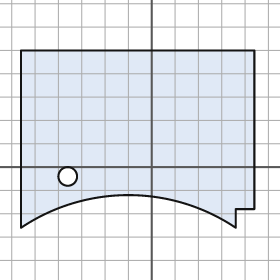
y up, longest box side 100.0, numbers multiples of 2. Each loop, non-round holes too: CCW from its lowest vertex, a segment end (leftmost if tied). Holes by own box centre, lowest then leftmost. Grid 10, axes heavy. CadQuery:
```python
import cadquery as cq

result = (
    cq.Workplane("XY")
    .moveTo(-56.0, -26.0)
    .threePointArc((-10.0, -12.0), (36.0, -26.0))
    .lineTo(36.0, -18.0)
    .lineTo(44.0, -18.0)
    .lineTo(44.0, 50.0)
    .lineTo(-56.0, 50.0)
    .close()
    .moveTo(-36.0, -4.0)
    .circle(4.0)
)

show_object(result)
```